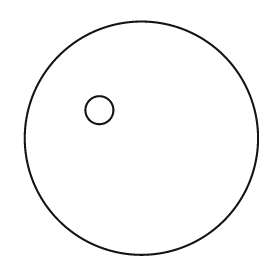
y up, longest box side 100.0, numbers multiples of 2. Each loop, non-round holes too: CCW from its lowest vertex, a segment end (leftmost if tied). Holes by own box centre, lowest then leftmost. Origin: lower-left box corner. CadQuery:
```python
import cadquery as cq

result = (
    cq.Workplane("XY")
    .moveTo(50.0, 50.0)
    .circle(50.0)
    .moveTo(32.0, 62.0)
    .circle(6.0)
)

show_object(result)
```